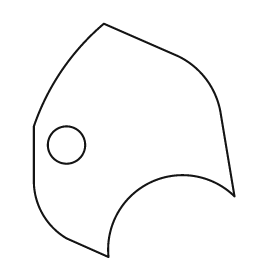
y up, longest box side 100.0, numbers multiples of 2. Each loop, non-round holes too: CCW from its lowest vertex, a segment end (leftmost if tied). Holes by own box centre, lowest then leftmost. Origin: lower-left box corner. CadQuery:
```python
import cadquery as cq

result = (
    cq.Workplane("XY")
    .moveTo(32.0, 0.0)
    .threePointArc((50.0, 32.0), (86.0, 26.0))
    .lineTo(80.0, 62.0)
    .threePointArc((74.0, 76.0), (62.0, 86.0))
    .lineTo(30.0, 100.0)
    .threePointArc((12.0, 80.0), (0.0, 56.0))
    .lineTo(0.0, 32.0)
    .threePointArc((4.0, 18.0), (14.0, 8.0))
    .close()
    .moveTo(14.0, 48.0)
    .circle(8.0)
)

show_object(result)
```